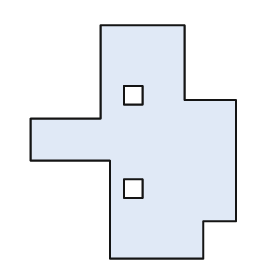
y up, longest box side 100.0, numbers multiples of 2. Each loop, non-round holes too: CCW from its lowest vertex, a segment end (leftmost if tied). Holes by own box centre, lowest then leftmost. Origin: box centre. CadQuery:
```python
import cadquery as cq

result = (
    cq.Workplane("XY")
    .moveTo(-10.0, -50.0)
    .lineTo(30.0, -50.0)
    .lineTo(30.0, -34.0)
    .lineTo(44.0, -34.0)
    .lineTo(44.0, 18.0)
    .lineTo(22.0, 18.0)
    .lineTo(22.0, 50.0)
    .lineTo(-14.0, 50.0)
    .lineTo(-14.0, 10.0)
    .lineTo(-44.0, 10.0)
    .lineTo(-44.0, -8.0)
    .lineTo(-10.0, -8.0)
    .close()
    .moveTo(-4.0, -24.0)
    .lineTo(4.0, -24.0)
    .lineTo(4.0, -16.0)
    .lineTo(-4.0, -16.0)
    .close()
    .moveTo(-4.0, 16.0)
    .lineTo(4.0, 16.0)
    .lineTo(4.0, 24.0)
    .lineTo(-4.0, 24.0)
    .close()
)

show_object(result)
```